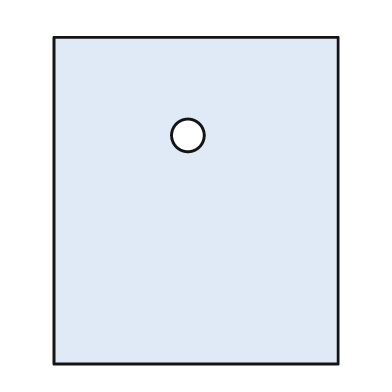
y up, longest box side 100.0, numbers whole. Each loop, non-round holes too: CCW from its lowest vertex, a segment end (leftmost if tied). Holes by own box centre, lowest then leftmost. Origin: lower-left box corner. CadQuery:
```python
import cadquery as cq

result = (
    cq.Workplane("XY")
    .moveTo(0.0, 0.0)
    .lineTo(87.0, 0.0)
    .lineTo(87.0, 100.0)
    .lineTo(0.0, 100.0)
    .close()
    .moveTo(41.0, 70.0)
    .circle(5.0)
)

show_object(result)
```